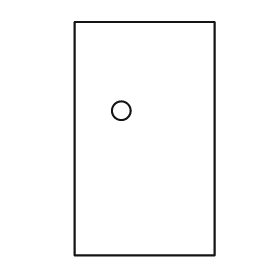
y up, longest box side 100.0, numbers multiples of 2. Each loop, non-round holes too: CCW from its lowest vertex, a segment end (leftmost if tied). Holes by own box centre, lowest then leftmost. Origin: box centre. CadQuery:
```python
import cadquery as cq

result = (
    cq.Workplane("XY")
    .moveTo(-30.0, -50.0)
    .lineTo(30.0, -50.0)
    .lineTo(30.0, 50.0)
    .lineTo(-30.0, 50.0)
    .close()
    .moveTo(-10.0, 12.0)
    .circle(4.0)
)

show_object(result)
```